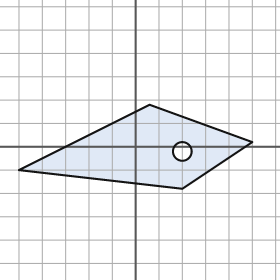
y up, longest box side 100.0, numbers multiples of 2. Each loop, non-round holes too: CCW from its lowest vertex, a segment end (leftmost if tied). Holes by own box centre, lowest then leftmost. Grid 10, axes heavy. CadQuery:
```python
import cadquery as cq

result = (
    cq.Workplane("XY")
    .moveTo(20.0, -18.0)
    .lineTo(50.0, 2.0)
    .lineTo(6.0, 18.0)
    .lineTo(-50.0, -10.0)
    .close()
    .moveTo(20.0, -2.0)
    .circle(4.0)
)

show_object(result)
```